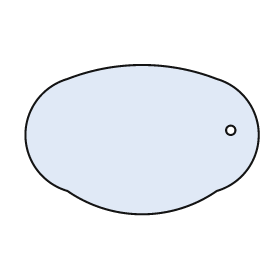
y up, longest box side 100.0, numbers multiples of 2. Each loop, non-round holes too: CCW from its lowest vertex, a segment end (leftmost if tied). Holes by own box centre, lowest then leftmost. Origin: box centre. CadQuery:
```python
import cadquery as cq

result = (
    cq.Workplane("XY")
    .moveTo(-32.0, -22.0)
    .threePointArc((0.0, -32.0), (32.0, -22.0))
    .threePointArc((50.0, 2.0), (32.0, 26.0))
    .threePointArc((0.0, 32.0), (-32.0, 26.0))
    .threePointArc((-50.0, 2.0), (-32.0, -22.0))
    .close()
    .moveTo(38.0, 4.0)
    .circle(2.0)
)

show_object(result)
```